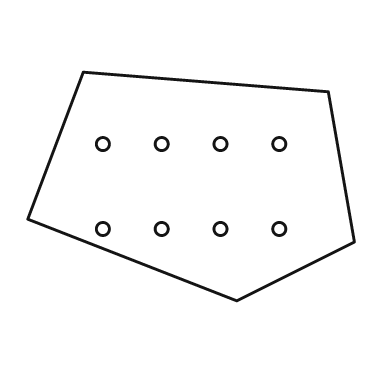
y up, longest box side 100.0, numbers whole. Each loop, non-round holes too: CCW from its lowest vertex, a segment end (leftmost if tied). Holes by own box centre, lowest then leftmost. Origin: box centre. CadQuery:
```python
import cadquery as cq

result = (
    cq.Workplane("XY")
    .moveTo(14.0, -35.0)
    .lineTo(50.0, -17.0)
    .lineTo(42.0, 29.0)
    .lineTo(-33.0, 35.0)
    .lineTo(-50.0, -10.0)
    .close()
    .moveTo(-27.0, -13.0)
    .circle(2.0)
    .moveTo(-9.0, -13.0)
    .circle(2.0)
    .moveTo(9.0, -13.0)
    .circle(2.0)
    .moveTo(27.0, -13.0)
    .circle(2.0)
    .moveTo(-27.0, 13.0)
    .circle(2.0)
    .moveTo(-9.0, 13.0)
    .circle(2.0)
    .moveTo(9.0, 13.0)
    .circle(2.0)
    .moveTo(27.0, 13.0)
    .circle(2.0)
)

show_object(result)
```